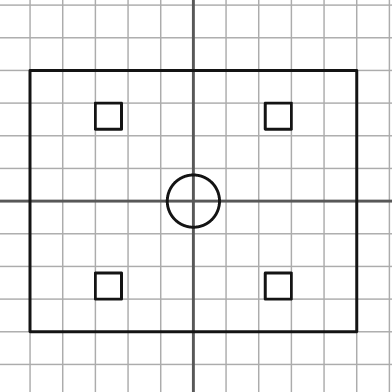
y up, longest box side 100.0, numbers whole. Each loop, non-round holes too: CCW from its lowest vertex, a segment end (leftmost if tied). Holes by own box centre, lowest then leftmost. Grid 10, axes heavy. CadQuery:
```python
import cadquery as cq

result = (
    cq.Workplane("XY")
    .moveTo(-50.0, -40.0)
    .lineTo(50.0, -40.0)
    .lineTo(50.0, 40.0)
    .lineTo(-50.0, 40.0)
    .close()
    .moveTo(-30.0, -30.0)
    .lineTo(-22.0, -30.0)
    .lineTo(-22.0, -22.0)
    .lineTo(-30.0, -22.0)
    .close()
    .moveTo(22.0, -30.0)
    .lineTo(30.0, -30.0)
    .lineTo(30.0, -22.0)
    .lineTo(22.0, -22.0)
    .close()
    .moveTo(0.0, 0.0)
    .circle(8.0)
    .moveTo(-30.0, 22.0)
    .lineTo(-22.0, 22.0)
    .lineTo(-22.0, 30.0)
    .lineTo(-30.0, 30.0)
    .close()
    .moveTo(22.0, 22.0)
    .lineTo(30.0, 22.0)
    .lineTo(30.0, 30.0)
    .lineTo(22.0, 30.0)
    .close()
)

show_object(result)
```